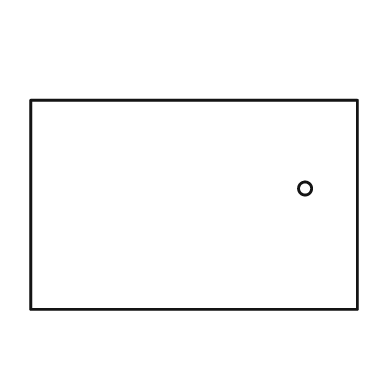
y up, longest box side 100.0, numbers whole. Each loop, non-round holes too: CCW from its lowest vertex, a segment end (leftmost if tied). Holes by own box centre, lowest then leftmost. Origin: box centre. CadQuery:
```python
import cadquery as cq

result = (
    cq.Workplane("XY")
    .moveTo(-50.0, -32.0)
    .lineTo(50.0, -32.0)
    .lineTo(50.0, 32.0)
    .lineTo(-50.0, 32.0)
    .close()
    .moveTo(34.0, 5.0)
    .circle(2.0)
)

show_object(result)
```